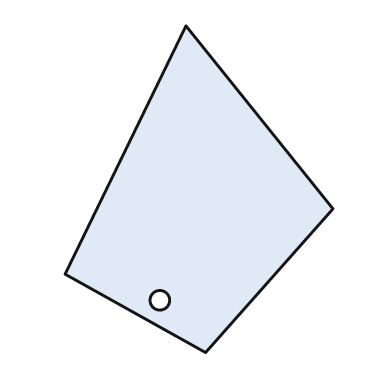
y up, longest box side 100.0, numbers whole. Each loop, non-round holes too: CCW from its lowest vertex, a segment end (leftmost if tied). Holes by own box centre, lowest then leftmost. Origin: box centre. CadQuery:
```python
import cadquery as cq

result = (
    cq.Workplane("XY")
    .moveTo(2.0, -50.0)
    .lineTo(41.0, -6.0)
    .lineTo(-4.0, 50.0)
    .lineTo(-41.0, -26.0)
    .close()
    .moveTo(-12.0, -34.0)
    .circle(3.0)
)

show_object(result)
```